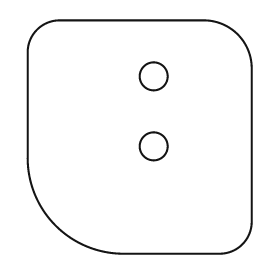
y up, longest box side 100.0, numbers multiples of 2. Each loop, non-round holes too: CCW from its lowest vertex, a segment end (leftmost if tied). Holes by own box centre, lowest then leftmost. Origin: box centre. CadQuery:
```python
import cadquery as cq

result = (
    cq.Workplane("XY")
    .moveTo(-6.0, -50.0)
    .lineTo(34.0, -50.0)
    .threePointArc((44.0, -46.0), (48.0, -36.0))
    .lineTo(48.0, 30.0)
    .threePointArc((42.0, 44.0), (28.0, 50.0))
    .lineTo(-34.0, 50.0)
    .threePointArc((-44.0, 46.0), (-48.0, 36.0))
    .lineTo(-48.0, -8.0)
    .threePointArc((-36.0, -38.0), (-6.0, -50.0))
    .close()
    .moveTo(6.0, -4.0)
    .circle(6.0)
    .moveTo(6.0, 26.0)
    .circle(6.0)
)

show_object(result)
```